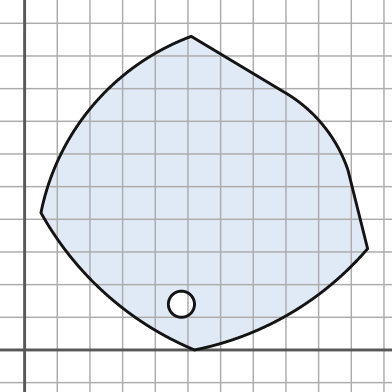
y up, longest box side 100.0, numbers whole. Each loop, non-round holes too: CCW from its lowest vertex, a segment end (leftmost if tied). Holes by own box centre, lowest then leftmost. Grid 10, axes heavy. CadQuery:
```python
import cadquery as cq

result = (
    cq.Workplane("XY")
    .moveTo(52.0, 0.0)
    .threePointArc((81.0, 11.0), (105.0, 31.0))
    .lineTo(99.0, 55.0)
    .threePointArc((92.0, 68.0), (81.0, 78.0))
    .lineTo(51.0, 96.0)
    .threePointArc((21.0, 75.0), (5.0, 42.0))
    .threePointArc((25.0, 17.0), (52.0, 0.0))
    .close()
    .moveTo(48.0, 14.0)
    .circle(4.0)
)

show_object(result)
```